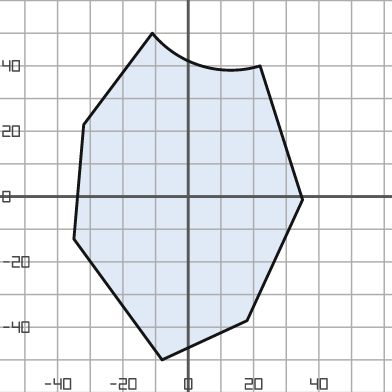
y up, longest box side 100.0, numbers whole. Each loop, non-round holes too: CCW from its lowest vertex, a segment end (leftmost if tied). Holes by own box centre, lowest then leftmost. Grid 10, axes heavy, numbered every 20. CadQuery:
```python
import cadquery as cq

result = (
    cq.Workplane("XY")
    .moveTo(-8.0, -50.0)
    .lineTo(18.0, -38.0)
    .lineTo(35.0, -1.0)
    .lineTo(22.0, 40.0)
    .threePointArc((4.0, 40.0), (-11.0, 50.0))
    .lineTo(-32.0, 22.0)
    .lineTo(-35.0, -13.0)
    .close()
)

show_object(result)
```